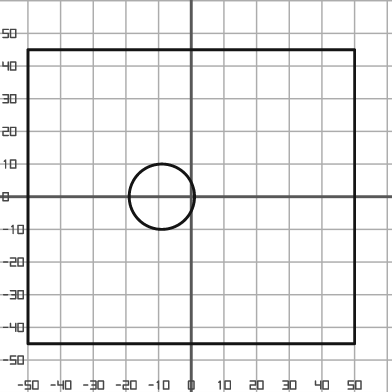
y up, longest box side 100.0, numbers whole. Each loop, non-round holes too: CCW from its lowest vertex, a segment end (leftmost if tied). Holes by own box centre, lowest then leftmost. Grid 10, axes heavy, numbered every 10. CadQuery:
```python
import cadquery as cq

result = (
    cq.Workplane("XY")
    .moveTo(-50.0, -45.0)
    .lineTo(50.0, -45.0)
    .lineTo(50.0, 45.0)
    .lineTo(-50.0, 45.0)
    .close()
    .moveTo(-9.0, 0.0)
    .circle(10.0)
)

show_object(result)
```